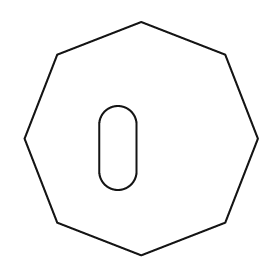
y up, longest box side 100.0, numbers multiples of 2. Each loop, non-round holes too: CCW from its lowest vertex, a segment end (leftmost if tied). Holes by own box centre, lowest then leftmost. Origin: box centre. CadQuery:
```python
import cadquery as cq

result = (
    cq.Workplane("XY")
    .moveTo(0.0, -50.0)
    .lineTo(36.0, -36.0)
    .lineTo(50.0, 0.0)
    .lineTo(36.0, 36.0)
    .lineTo(0.0, 50.0)
    .lineTo(-36.0, 36.0)
    .lineTo(-50.0, 0.0)
    .lineTo(-36.0, -36.0)
    .close()
    .moveTo(-18.0, -14.0)
    .threePointArc((-10.0, -22.0), (-2.0, -14.0))
    .lineTo(-2.0, 6.0)
    .threePointArc((-10.0, 14.0), (-18.0, 6.0))
    .close()
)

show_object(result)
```